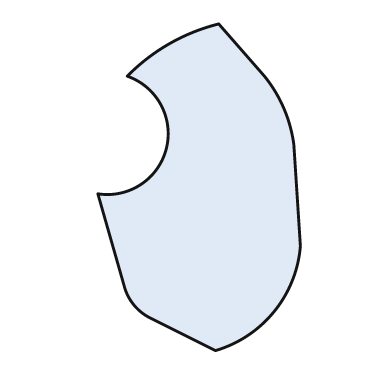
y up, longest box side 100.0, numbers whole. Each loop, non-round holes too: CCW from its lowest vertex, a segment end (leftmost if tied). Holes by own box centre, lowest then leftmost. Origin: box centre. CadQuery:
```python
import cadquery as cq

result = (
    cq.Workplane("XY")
    .moveTo(5.0, -50.0)
    .threePointArc((23.0, -38.0), (31.0, -18.0))
    .lineTo(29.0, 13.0)
    .threePointArc((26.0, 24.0), (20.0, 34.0))
    .lineTo(6.0, 50.0)
    .threePointArc((-9.0, 44.0), (-22.0, 34.0))
    .threePointArc((-10.0, 12.0), (-31.0, -2.0))
    .lineTo(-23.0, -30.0)
    .threePointArc((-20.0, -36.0), (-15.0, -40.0))
    .close()
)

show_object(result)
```